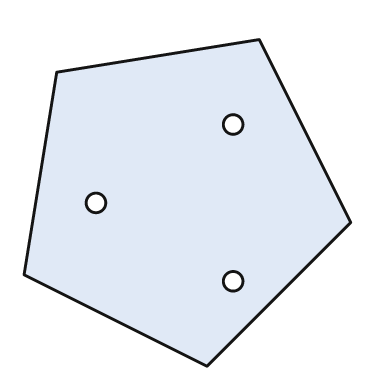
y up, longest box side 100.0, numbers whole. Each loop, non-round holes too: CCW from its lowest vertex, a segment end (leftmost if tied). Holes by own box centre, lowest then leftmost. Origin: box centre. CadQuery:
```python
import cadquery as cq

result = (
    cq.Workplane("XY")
    .moveTo(6.0, -50.0)
    .lineTo(50.0, -6.0)
    .lineTo(22.0, 50.0)
    .lineTo(-40.0, 40.0)
    .lineTo(-50.0, -22.0)
    .close()
    .moveTo(14.0, -24.0)
    .circle(3.0)
    .moveTo(-28.0, 0.0)
    .circle(3.0)
    .moveTo(14.0, 24.0)
    .circle(3.0)
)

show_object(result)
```